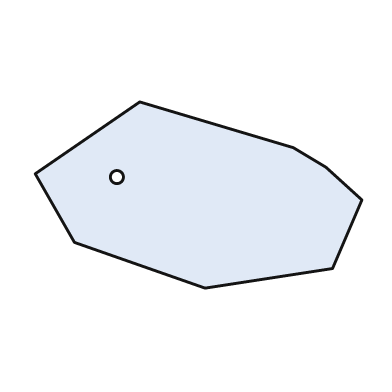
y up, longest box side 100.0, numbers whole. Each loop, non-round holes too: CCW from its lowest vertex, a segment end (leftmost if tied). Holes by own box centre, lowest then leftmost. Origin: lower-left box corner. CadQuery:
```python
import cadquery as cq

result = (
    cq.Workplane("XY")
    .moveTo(52.0, 0.0)
    .lineTo(91.0, 6.0)
    .lineTo(100.0, 27.0)
    .lineTo(89.0, 37.0)
    .lineTo(79.0, 43.0)
    .lineTo(32.0, 57.0)
    .lineTo(0.0, 35.0)
    .lineTo(12.0, 14.0)
    .close()
    .moveTo(25.0, 34.0)
    .circle(2.0)
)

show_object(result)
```